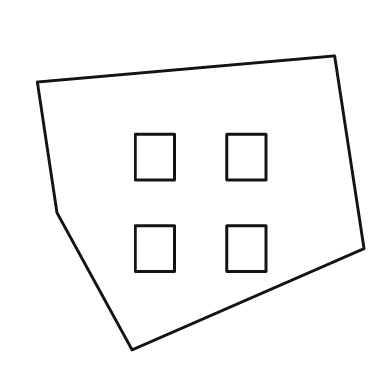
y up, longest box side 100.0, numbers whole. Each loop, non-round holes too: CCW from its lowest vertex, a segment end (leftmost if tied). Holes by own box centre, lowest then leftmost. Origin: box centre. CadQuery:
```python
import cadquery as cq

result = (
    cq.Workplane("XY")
    .moveTo(-21.0, -45.0)
    .lineTo(50.0, -14.0)
    .lineTo(41.0, 45.0)
    .lineTo(-50.0, 37.0)
    .lineTo(-44.0, -3.0)
    .close()
    .moveTo(-20.0, -21.0)
    .lineTo(-8.0, -21.0)
    .lineTo(-8.0, -7.0)
    .lineTo(-20.0, -7.0)
    .close()
    .moveTo(8.0, -21.0)
    .lineTo(20.0, -21.0)
    .lineTo(20.0, -7.0)
    .lineTo(8.0, -7.0)
    .close()
    .moveTo(-20.0, 7.0)
    .lineTo(-8.0, 7.0)
    .lineTo(-8.0, 21.0)
    .lineTo(-20.0, 21.0)
    .close()
    .moveTo(8.0, 7.0)
    .lineTo(20.0, 7.0)
    .lineTo(20.0, 21.0)
    .lineTo(8.0, 21.0)
    .close()
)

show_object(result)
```